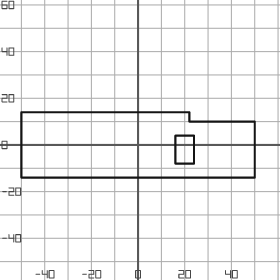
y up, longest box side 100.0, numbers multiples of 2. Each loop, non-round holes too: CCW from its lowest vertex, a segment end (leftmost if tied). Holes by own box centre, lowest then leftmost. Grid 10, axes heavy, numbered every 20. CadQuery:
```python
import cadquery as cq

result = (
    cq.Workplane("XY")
    .moveTo(-50.0, -14.0)
    .lineTo(50.0, -14.0)
    .lineTo(50.0, 10.0)
    .lineTo(22.0, 10.0)
    .lineTo(22.0, 14.0)
    .lineTo(-50.0, 14.0)
    .close()
    .moveTo(16.0, -8.0)
    .lineTo(24.0, -8.0)
    .lineTo(24.0, 4.0)
    .lineTo(16.0, 4.0)
    .close()
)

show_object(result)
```